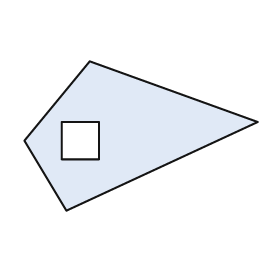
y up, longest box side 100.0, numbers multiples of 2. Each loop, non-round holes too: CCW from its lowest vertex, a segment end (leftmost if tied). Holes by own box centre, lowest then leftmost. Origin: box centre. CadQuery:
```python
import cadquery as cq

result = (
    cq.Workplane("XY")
    .moveTo(-32.0, -32.0)
    .lineTo(50.0, 6.0)
    .lineTo(-22.0, 32.0)
    .lineTo(-50.0, -2.0)
    .close()
    .moveTo(-34.0, -10.0)
    .lineTo(-18.0, -10.0)
    .lineTo(-18.0, 6.0)
    .lineTo(-34.0, 6.0)
    .close()
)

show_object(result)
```